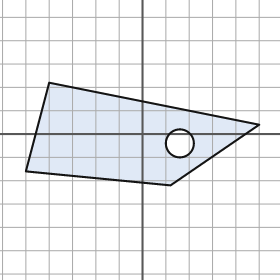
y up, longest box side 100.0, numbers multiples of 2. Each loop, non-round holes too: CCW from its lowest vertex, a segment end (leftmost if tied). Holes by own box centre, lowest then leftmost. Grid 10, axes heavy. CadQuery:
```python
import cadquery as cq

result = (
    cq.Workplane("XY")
    .moveTo(12.0, -22.0)
    .lineTo(50.0, 4.0)
    .lineTo(-40.0, 22.0)
    .lineTo(-50.0, -16.0)
    .close()
    .moveTo(16.0, -4.0)
    .circle(6.0)
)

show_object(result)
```